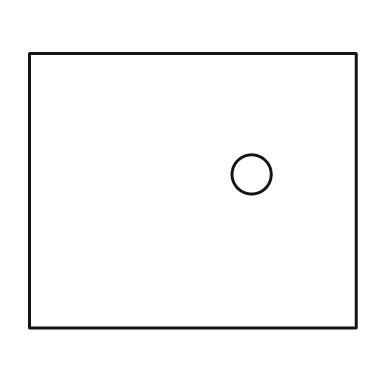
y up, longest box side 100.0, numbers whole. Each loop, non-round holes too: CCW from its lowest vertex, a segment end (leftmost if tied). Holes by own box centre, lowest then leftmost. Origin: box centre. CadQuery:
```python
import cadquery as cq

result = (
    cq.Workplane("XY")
    .moveTo(-50.0, -42.0)
    .lineTo(50.0, -42.0)
    .lineTo(50.0, 42.0)
    .lineTo(-50.0, 42.0)
    .close()
    .moveTo(18.0, 5.0)
    .circle(6.0)
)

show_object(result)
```